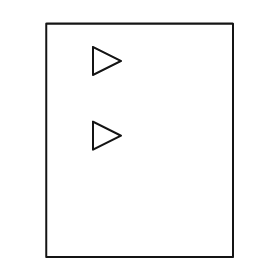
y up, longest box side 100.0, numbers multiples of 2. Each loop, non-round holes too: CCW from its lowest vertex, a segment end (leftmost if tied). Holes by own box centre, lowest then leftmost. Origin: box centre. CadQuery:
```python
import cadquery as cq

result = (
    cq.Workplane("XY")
    .moveTo(-40.0, -50.0)
    .lineTo(40.0, -50.0)
    .lineTo(40.0, 50.0)
    .lineTo(-40.0, 50.0)
    .close()
    .moveTo(-20.0, -4.0)
    .lineTo(-8.0, 2.0)
    .lineTo(-20.0, 8.0)
    .close()
    .moveTo(-20.0, 28.0)
    .lineTo(-8.0, 34.0)
    .lineTo(-20.0, 40.0)
    .close()
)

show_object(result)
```